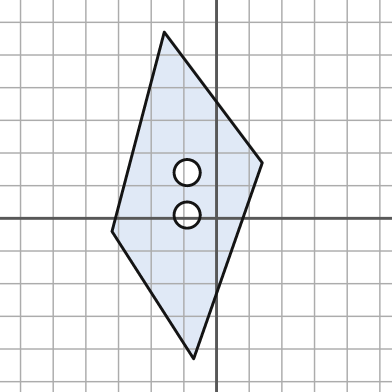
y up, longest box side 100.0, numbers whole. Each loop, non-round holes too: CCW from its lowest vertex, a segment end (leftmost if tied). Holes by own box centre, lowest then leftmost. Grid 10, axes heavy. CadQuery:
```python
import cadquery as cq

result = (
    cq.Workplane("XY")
    .moveTo(-7.0, -43.0)
    .lineTo(14.0, 17.0)
    .lineTo(-16.0, 57.0)
    .lineTo(-32.0, -4.0)
    .close()
    .moveTo(-9.0, 1.0)
    .circle(4.0)
    .moveTo(-9.0, 14.0)
    .circle(4.0)
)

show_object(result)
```